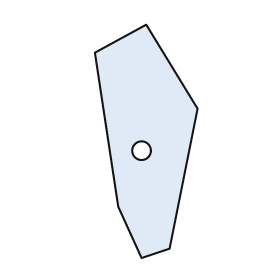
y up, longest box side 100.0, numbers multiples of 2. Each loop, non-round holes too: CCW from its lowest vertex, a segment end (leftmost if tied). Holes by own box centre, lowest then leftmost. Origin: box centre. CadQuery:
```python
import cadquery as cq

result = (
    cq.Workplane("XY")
    .moveTo(-2.0, -50.0)
    .lineTo(10.0, -46.0)
    .lineTo(22.0, 14.0)
    .lineTo(0.0, 50.0)
    .lineTo(-22.0, 38.0)
    .lineTo(-12.0, -28.0)
    .close()
    .moveTo(-2.0, -4.0)
    .circle(4.0)
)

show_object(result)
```